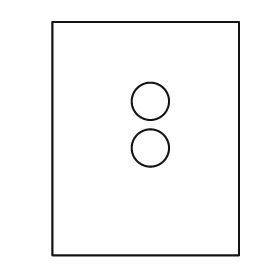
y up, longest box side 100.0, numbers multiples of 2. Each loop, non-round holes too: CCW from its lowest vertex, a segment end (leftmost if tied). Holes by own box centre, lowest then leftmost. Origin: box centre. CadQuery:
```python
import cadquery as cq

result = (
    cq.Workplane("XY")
    .moveTo(-40.0, -50.0)
    .lineTo(40.0, -50.0)
    .lineTo(40.0, 50.0)
    .lineTo(-40.0, 50.0)
    .close()
    .moveTo(2.0, -4.0)
    .circle(8.0)
    .moveTo(2.0, 16.0)
    .circle(8.0)
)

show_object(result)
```